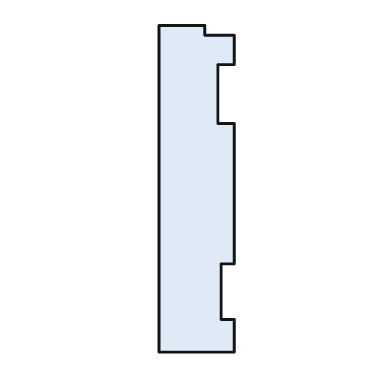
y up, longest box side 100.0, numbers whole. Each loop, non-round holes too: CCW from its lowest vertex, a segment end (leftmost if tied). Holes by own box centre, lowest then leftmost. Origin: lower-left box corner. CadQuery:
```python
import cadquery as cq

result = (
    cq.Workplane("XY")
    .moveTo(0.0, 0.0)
    .lineTo(23.0, 0.0)
    .lineTo(23.0, 10.0)
    .lineTo(19.0, 10.0)
    .lineTo(19.0, 27.0)
    .lineTo(23.0, 27.0)
    .lineTo(23.0, 70.0)
    .lineTo(18.0, 70.0)
    .lineTo(18.0, 88.0)
    .lineTo(23.0, 88.0)
    .lineTo(23.0, 97.0)
    .lineTo(14.0, 97.0)
    .lineTo(14.0, 100.0)
    .lineTo(0.0, 100.0)
    .close()
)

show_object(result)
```